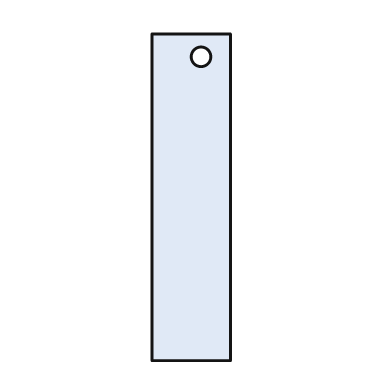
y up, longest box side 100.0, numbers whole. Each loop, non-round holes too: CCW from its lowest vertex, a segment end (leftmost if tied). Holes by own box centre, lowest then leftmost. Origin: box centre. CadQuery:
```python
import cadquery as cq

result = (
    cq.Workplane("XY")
    .moveTo(-12.0, -50.0)
    .lineTo(12.0, -50.0)
    .lineTo(12.0, 50.0)
    .lineTo(-12.0, 50.0)
    .close()
    .moveTo(3.0, 43.0)
    .circle(3.0)
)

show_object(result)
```